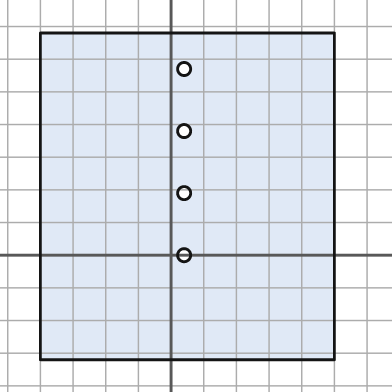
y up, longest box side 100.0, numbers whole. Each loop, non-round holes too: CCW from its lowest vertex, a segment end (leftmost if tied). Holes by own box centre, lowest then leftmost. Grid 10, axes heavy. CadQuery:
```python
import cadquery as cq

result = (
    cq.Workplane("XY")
    .moveTo(-40.0, -32.0)
    .lineTo(50.0, -32.0)
    .lineTo(50.0, 68.0)
    .lineTo(-40.0, 68.0)
    .close()
    .moveTo(4.0, 0.0)
    .circle(2.0)
    .moveTo(4.0, 19.0)
    .circle(2.0)
    .moveTo(4.0, 38.0)
    .circle(2.0)
    .moveTo(4.0, 57.0)
    .circle(2.0)
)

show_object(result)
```